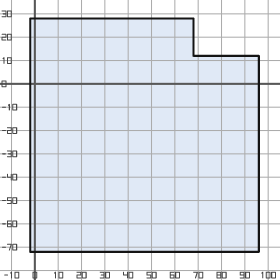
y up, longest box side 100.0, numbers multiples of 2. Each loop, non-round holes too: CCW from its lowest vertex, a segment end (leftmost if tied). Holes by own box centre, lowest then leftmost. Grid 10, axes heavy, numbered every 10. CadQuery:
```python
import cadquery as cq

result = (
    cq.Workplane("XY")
    .moveTo(-2.0, -72.0)
    .lineTo(96.0, -72.0)
    .lineTo(96.0, 12.0)
    .lineTo(68.0, 12.0)
    .lineTo(68.0, 28.0)
    .lineTo(-2.0, 28.0)
    .close()
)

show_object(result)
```